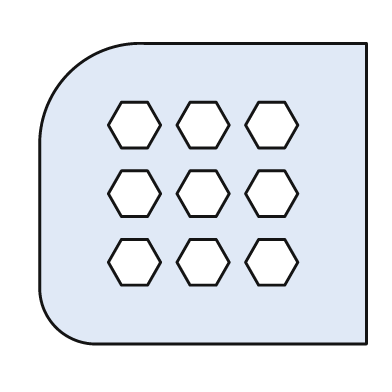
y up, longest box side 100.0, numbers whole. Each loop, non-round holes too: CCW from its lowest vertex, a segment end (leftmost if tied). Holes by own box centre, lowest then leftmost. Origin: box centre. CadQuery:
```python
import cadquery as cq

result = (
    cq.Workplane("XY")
    .moveTo(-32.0, -46.0)
    .lineTo(50.0, -46.0)
    .lineTo(50.0, 46.0)
    .lineTo(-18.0, 46.0)
    .threePointArc((-41.0, 37.0), (-50.0, 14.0))
    .lineTo(-50.0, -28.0)
    .threePointArc((-45.0, -41.0), (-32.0, -46.0))
    .close()
    .moveTo(-25.0, -28.0)
    .lineTo(-17.0, -28.0)
    .lineTo(-13.0, -21.0)
    .lineTo(-17.0, -14.0)
    .lineTo(-25.0, -14.0)
    .lineTo(-29.0, -21.0)
    .close()
    .moveTo(-4.0, -28.0)
    .lineTo(4.0, -28.0)
    .lineTo(8.0, -21.0)
    .lineTo(4.0, -14.0)
    .lineTo(-4.0, -14.0)
    .lineTo(-8.0, -21.0)
    .close()
    .moveTo(17.0, -28.0)
    .lineTo(25.0, -28.0)
    .lineTo(29.0, -21.0)
    .lineTo(25.0, -14.0)
    .lineTo(17.0, -14.0)
    .lineTo(13.0, -21.0)
    .close()
    .moveTo(-25.0, -7.0)
    .lineTo(-17.0, -7.0)
    .lineTo(-13.0, 0.0)
    .lineTo(-17.0, 7.0)
    .lineTo(-25.0, 7.0)
    .lineTo(-29.0, 0.0)
    .close()
    .moveTo(-4.0, -7.0)
    .lineTo(4.0, -7.0)
    .lineTo(8.0, 0.0)
    .lineTo(4.0, 7.0)
    .lineTo(-4.0, 7.0)
    .lineTo(-8.0, 0.0)
    .close()
    .moveTo(17.0, -7.0)
    .lineTo(25.0, -7.0)
    .lineTo(29.0, 0.0)
    .lineTo(25.0, 7.0)
    .lineTo(17.0, 7.0)
    .lineTo(13.0, 0.0)
    .close()
    .moveTo(-25.0, 14.0)
    .lineTo(-17.0, 14.0)
    .lineTo(-13.0, 21.0)
    .lineTo(-17.0, 28.0)
    .lineTo(-25.0, 28.0)
    .lineTo(-29.0, 21.0)
    .close()
    .moveTo(-4.0, 14.0)
    .lineTo(4.0, 14.0)
    .lineTo(8.0, 21.0)
    .lineTo(4.0, 28.0)
    .lineTo(-4.0, 28.0)
    .lineTo(-8.0, 21.0)
    .close()
    .moveTo(17.0, 14.0)
    .lineTo(25.0, 14.0)
    .lineTo(29.0, 21.0)
    .lineTo(25.0, 28.0)
    .lineTo(17.0, 28.0)
    .lineTo(13.0, 21.0)
    .close()
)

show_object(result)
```